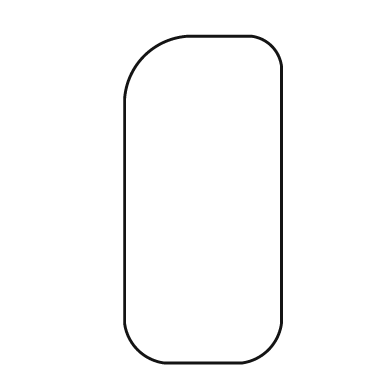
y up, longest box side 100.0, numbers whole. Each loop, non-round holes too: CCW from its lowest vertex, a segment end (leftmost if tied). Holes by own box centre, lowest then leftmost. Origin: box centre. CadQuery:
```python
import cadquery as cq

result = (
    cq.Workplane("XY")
    .moveTo(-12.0, -50.0)
    .lineTo(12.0, -50.0)
    .threePointArc((20.0, -46.0), (24.0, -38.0))
    .lineTo(24.0, 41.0)
    .threePointArc((21.0, 47.0), (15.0, 50.0))
    .lineTo(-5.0, 50.0)
    .threePointArc((-18.0, 44.0), (-24.0, 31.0))
    .lineTo(-24.0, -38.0)
    .threePointArc((-20.0, -46.0), (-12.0, -50.0))
    .close()
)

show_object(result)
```